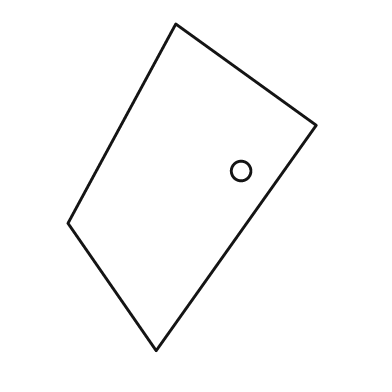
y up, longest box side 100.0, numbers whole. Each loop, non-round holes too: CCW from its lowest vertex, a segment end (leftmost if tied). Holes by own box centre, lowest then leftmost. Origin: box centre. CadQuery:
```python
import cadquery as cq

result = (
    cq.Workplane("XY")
    .moveTo(-11.0, -50.0)
    .lineTo(38.0, 19.0)
    .lineTo(-5.0, 50.0)
    .lineTo(-38.0, -11.0)
    .close()
    .moveTo(15.0, 5.0)
    .circle(3.0)
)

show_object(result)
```